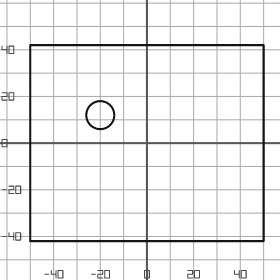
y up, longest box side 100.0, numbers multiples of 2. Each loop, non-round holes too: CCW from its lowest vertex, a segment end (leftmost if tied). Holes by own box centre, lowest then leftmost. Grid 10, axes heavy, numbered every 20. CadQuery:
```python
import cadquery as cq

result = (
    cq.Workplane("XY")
    .moveTo(-50.0, -42.0)
    .lineTo(50.0, -42.0)
    .lineTo(50.0, 42.0)
    .lineTo(-50.0, 42.0)
    .close()
    .moveTo(-20.0, 12.0)
    .circle(6.0)
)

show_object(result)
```